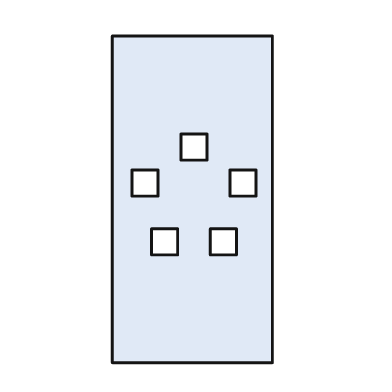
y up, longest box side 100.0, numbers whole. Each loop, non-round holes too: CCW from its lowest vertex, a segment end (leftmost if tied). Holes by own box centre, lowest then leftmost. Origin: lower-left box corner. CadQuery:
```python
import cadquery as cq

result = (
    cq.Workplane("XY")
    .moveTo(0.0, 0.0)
    .lineTo(49.0, 0.0)
    .lineTo(49.0, 100.0)
    .lineTo(0.0, 100.0)
    .close()
    .moveTo(12.0, 33.0)
    .lineTo(20.0, 33.0)
    .lineTo(20.0, 41.0)
    .lineTo(12.0, 41.0)
    .close()
    .moveTo(30.0, 33.0)
    .lineTo(38.0, 33.0)
    .lineTo(38.0, 41.0)
    .lineTo(30.0, 41.0)
    .close()
    .moveTo(6.0, 51.0)
    .lineTo(14.0, 51.0)
    .lineTo(14.0, 59.0)
    .lineTo(6.0, 59.0)
    .close()
    .moveTo(36.0, 51.0)
    .lineTo(44.0, 51.0)
    .lineTo(44.0, 59.0)
    .lineTo(36.0, 59.0)
    .close()
    .moveTo(21.0, 62.0)
    .lineTo(29.0, 62.0)
    .lineTo(29.0, 70.0)
    .lineTo(21.0, 70.0)
    .close()
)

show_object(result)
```